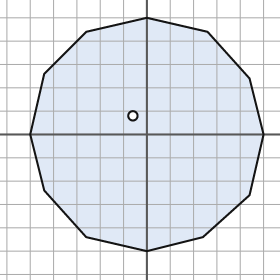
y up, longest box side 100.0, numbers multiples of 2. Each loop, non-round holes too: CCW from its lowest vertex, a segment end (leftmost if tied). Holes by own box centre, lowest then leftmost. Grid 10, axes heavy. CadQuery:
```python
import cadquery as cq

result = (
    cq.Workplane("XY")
    .moveTo(0.0, -50.0)
    .lineTo(24.0, -44.0)
    .lineTo(44.0, -26.0)
    .lineTo(50.0, 0.0)
    .lineTo(44.0, 24.0)
    .lineTo(26.0, 44.0)
    .lineTo(0.0, 50.0)
    .lineTo(-26.0, 44.0)
    .lineTo(-44.0, 26.0)
    .lineTo(-50.0, 0.0)
    .lineTo(-44.0, -24.0)
    .lineTo(-26.0, -44.0)
    .close()
    .moveTo(-6.0, 8.0)
    .circle(2.0)
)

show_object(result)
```